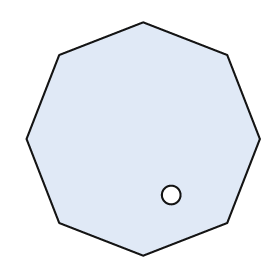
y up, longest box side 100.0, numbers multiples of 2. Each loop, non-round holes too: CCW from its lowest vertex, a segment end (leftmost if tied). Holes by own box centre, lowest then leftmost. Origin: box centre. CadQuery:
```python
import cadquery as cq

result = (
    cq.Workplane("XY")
    .moveTo(0.0, -50.0)
    .lineTo(36.0, -36.0)
    .lineTo(50.0, 0.0)
    .lineTo(36.0, 36.0)
    .lineTo(0.0, 50.0)
    .lineTo(-36.0, 36.0)
    .lineTo(-50.0, 0.0)
    .lineTo(-36.0, -36.0)
    .close()
    .moveTo(12.0, -24.0)
    .circle(4.0)
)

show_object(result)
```